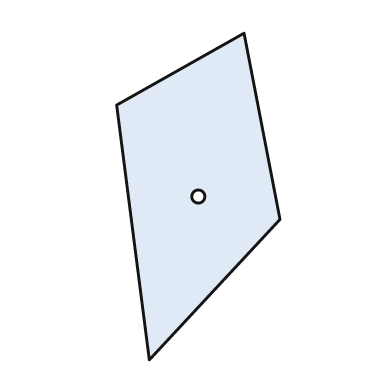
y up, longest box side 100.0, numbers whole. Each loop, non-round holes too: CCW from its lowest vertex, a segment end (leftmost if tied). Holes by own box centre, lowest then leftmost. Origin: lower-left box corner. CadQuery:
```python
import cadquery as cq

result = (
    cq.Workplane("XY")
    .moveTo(10.0, 0.0)
    .lineTo(50.0, 43.0)
    .lineTo(39.0, 100.0)
    .lineTo(0.0, 78.0)
    .close()
    .moveTo(25.0, 50.0)
    .circle(2.0)
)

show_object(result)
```